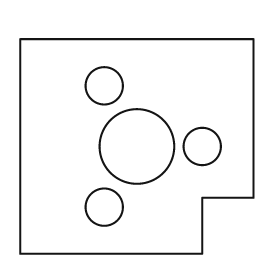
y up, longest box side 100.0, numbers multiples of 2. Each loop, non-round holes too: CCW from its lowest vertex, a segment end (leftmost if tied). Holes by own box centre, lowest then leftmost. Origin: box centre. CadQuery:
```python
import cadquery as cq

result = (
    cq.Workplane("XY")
    .moveTo(-50.0, -46.0)
    .lineTo(28.0, -46.0)
    .lineTo(28.0, -22.0)
    .lineTo(50.0, -22.0)
    .lineTo(50.0, 46.0)
    .lineTo(-50.0, 46.0)
    .close()
    .moveTo(-14.0, -26.0)
    .circle(8.0)
    .moveTo(0.0, 0.0)
    .circle(16.0)
    .moveTo(28.0, 0.0)
    .circle(8.0)
    .moveTo(-14.0, 26.0)
    .circle(8.0)
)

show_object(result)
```